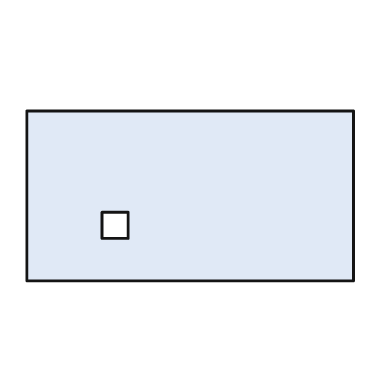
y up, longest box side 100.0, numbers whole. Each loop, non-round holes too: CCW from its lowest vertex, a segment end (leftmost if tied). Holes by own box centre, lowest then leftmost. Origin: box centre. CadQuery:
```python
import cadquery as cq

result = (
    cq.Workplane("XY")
    .moveTo(-50.0, -26.0)
    .lineTo(50.0, -26.0)
    .lineTo(50.0, 26.0)
    .lineTo(-50.0, 26.0)
    .close()
    .moveTo(-27.0, -13.0)
    .lineTo(-19.0, -13.0)
    .lineTo(-19.0, -5.0)
    .lineTo(-27.0, -5.0)
    .close()
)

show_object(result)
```